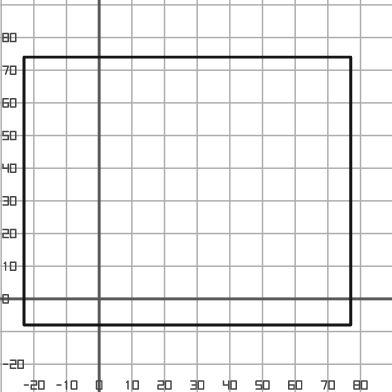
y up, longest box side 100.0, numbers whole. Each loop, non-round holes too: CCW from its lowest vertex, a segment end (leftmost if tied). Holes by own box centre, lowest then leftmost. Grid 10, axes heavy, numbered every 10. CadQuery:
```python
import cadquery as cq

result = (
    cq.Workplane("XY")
    .moveTo(-23.0, -8.0)
    .lineTo(77.0, -8.0)
    .lineTo(77.0, 74.0)
    .lineTo(-23.0, 74.0)
    .close()
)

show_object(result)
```